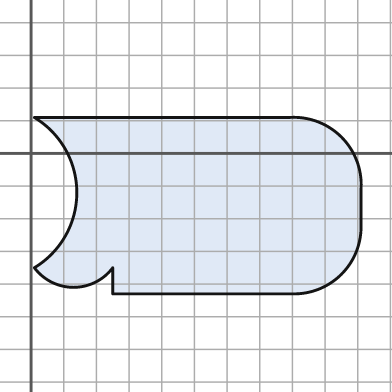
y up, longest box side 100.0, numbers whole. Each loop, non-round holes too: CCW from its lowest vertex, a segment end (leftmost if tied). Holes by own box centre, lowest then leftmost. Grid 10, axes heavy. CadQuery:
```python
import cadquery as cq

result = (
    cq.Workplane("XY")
    .moveTo(25.0, -43.0)
    .lineTo(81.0, -43.0)
    .threePointArc((95.0, -37.0), (101.0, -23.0))
    .lineTo(101.0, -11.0)
    .threePointArc((95.0, 5.0), (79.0, 11.0))
    .lineTo(1.0, 11.0)
    .threePointArc((14.0, -12.0), (1.0, -35.0))
    .threePointArc((13.0, -41.0), (25.0, -35.0))
    .close()
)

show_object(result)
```